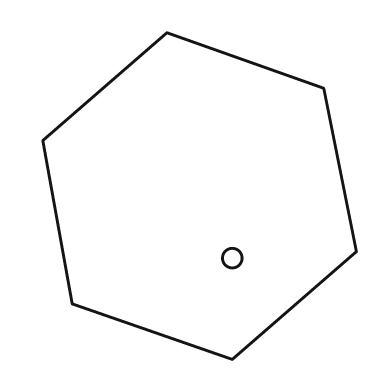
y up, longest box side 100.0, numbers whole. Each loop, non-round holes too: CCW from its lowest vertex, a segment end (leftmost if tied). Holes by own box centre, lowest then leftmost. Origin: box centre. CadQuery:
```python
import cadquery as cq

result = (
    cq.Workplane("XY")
    .moveTo(10.0, -50.0)
    .lineTo(48.0, -17.0)
    .lineTo(38.0, 33.0)
    .lineTo(-10.0, 50.0)
    .lineTo(-48.0, 17.0)
    .lineTo(-39.0, -33.0)
    .close()
    .moveTo(10.0, -19.0)
    .circle(3.0)
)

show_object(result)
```